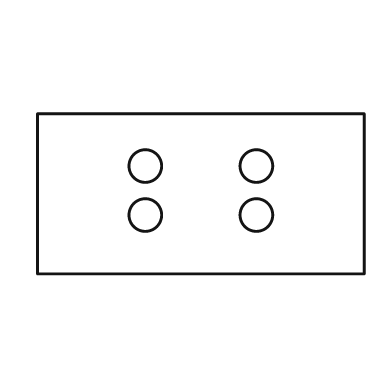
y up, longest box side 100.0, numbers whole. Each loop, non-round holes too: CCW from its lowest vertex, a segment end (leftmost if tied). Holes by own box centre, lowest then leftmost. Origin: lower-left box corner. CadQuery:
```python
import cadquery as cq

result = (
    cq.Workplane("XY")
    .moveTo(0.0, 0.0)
    .lineTo(100.0, 0.0)
    .lineTo(100.0, 49.0)
    .lineTo(0.0, 49.0)
    .close()
    .moveTo(33.0, 18.0)
    .circle(5.0)
    .moveTo(67.0, 18.0)
    .circle(5.0)
    .moveTo(33.0, 33.0)
    .circle(5.0)
    .moveTo(67.0, 33.0)
    .circle(5.0)
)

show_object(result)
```